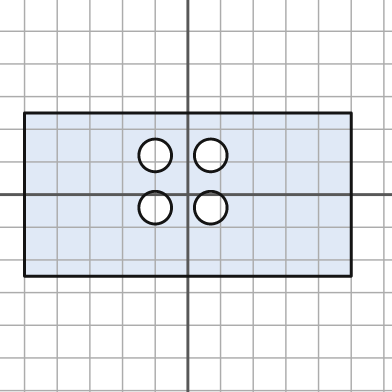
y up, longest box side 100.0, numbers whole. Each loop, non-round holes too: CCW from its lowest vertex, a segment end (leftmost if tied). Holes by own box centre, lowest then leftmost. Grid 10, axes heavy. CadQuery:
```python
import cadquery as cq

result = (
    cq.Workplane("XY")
    .moveTo(-50.0, -25.0)
    .lineTo(50.0, -25.0)
    .lineTo(50.0, 25.0)
    .lineTo(-50.0, 25.0)
    .close()
    .moveTo(-10.0, -4.0)
    .circle(5.0)
    .moveTo(7.0, -4.0)
    .circle(5.0)
    .moveTo(-10.0, 12.0)
    .circle(5.0)
    .moveTo(7.0, 12.0)
    .circle(5.0)
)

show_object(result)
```